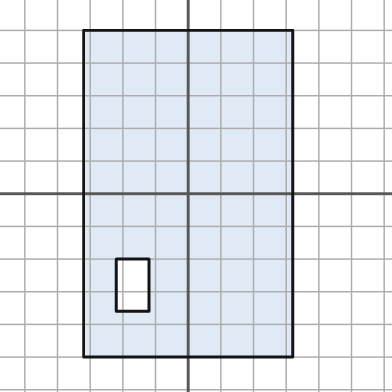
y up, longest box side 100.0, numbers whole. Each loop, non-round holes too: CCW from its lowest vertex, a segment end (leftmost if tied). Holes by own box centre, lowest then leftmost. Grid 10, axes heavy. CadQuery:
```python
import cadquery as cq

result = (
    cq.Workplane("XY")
    .moveTo(-32.0, -50.0)
    .lineTo(32.0, -50.0)
    .lineTo(32.0, 50.0)
    .lineTo(-32.0, 50.0)
    .close()
    .moveTo(-22.0, -36.0)
    .lineTo(-12.0, -36.0)
    .lineTo(-12.0, -20.0)
    .lineTo(-22.0, -20.0)
    .close()
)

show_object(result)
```